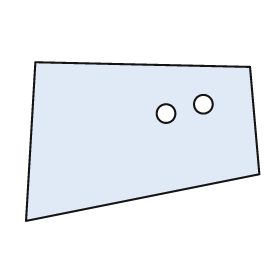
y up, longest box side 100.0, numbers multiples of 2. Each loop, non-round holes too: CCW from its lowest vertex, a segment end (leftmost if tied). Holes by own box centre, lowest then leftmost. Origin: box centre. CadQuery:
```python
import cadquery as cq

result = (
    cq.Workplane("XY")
    .moveTo(-50.0, -34.0)
    .lineTo(50.0, -14.0)
    .lineTo(46.0, 32.0)
    .lineTo(-46.0, 34.0)
    .close()
    .moveTo(10.0, 12.0)
    .circle(4.0)
    .moveTo(26.0, 16.0)
    .circle(4.0)
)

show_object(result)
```